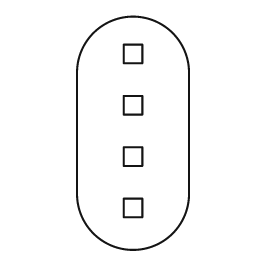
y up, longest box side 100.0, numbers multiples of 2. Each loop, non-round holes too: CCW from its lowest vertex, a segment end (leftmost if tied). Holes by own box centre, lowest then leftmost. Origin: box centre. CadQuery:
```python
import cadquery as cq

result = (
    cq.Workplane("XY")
    .moveTo(-24.0, -26.0)
    .threePointArc((0.0, -50.0), (24.0, -26.0))
    .lineTo(24.0, 26.0)
    .threePointArc((0.0, 50.0), (-24.0, 26.0))
    .close()
    .moveTo(-4.0, -36.0)
    .lineTo(4.0, -36.0)
    .lineTo(4.0, -28.0)
    .lineTo(-4.0, -28.0)
    .close()
    .moveTo(-4.0, -14.0)
    .lineTo(4.0, -14.0)
    .lineTo(4.0, -6.0)
    .lineTo(-4.0, -6.0)
    .close()
    .moveTo(-4.0, 8.0)
    .lineTo(4.0, 8.0)
    .lineTo(4.0, 16.0)
    .lineTo(-4.0, 16.0)
    .close()
    .moveTo(-4.0, 30.0)
    .lineTo(4.0, 30.0)
    .lineTo(4.0, 38.0)
    .lineTo(-4.0, 38.0)
    .close()
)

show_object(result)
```